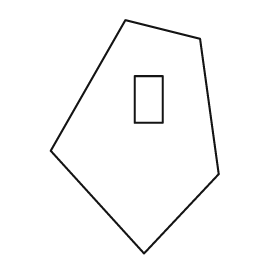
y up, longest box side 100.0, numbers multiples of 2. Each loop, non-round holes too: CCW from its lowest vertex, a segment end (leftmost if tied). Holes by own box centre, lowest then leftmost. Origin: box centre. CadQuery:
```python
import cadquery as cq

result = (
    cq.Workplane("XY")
    .moveTo(4.0, -50.0)
    .lineTo(36.0, -16.0)
    .lineTo(28.0, 42.0)
    .lineTo(-4.0, 50.0)
    .lineTo(-36.0, -6.0)
    .close()
    .moveTo(0.0, 6.0)
    .lineTo(12.0, 6.0)
    .lineTo(12.0, 26.0)
    .lineTo(0.0, 26.0)
    .close()
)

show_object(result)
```